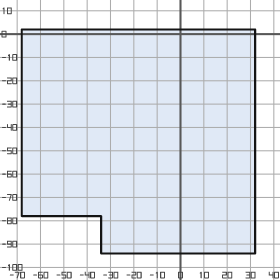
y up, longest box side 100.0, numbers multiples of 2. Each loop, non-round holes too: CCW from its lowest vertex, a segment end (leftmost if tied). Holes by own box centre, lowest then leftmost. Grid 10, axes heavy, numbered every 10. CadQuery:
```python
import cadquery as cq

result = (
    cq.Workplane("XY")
    .moveTo(-34.0, -94.0)
    .lineTo(32.0, -94.0)
    .lineTo(32.0, 2.0)
    .lineTo(-68.0, 2.0)
    .lineTo(-68.0, -78.0)
    .lineTo(-34.0, -78.0)
    .close()
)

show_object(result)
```